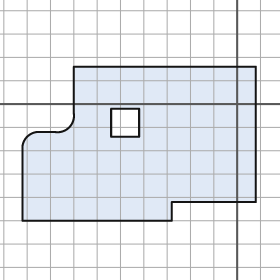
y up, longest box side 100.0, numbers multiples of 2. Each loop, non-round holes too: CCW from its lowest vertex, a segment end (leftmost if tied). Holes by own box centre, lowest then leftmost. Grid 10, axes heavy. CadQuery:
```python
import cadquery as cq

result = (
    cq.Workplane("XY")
    .moveTo(-92.0, -50.0)
    .lineTo(-28.0, -50.0)
    .lineTo(-28.0, -42.0)
    .lineTo(8.0, -42.0)
    .lineTo(8.0, 16.0)
    .lineTo(-70.0, 16.0)
    .lineTo(-70.0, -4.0)
    .threePointArc((-72.0, -10.0), (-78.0, -12.0))
    .lineTo(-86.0, -12.0)
    .threePointArc((-90.0, -14.0), (-92.0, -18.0))
    .close()
    .moveTo(-54.0, -14.0)
    .lineTo(-42.0, -14.0)
    .lineTo(-42.0, -2.0)
    .lineTo(-54.0, -2.0)
    .close()
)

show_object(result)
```